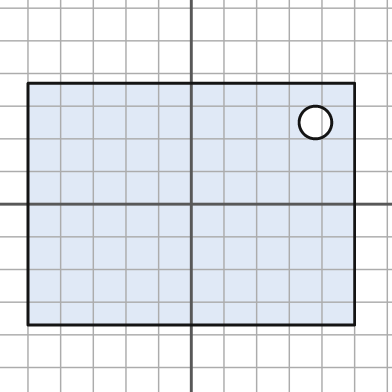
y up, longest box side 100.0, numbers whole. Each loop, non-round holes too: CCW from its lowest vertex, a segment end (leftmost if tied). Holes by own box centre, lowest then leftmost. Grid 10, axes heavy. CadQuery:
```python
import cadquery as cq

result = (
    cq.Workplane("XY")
    .moveTo(-50.0, -37.0)
    .lineTo(50.0, -37.0)
    .lineTo(50.0, 37.0)
    .lineTo(-50.0, 37.0)
    .close()
    .moveTo(38.0, 25.0)
    .circle(5.0)
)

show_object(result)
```